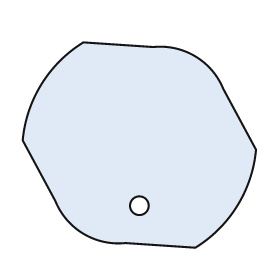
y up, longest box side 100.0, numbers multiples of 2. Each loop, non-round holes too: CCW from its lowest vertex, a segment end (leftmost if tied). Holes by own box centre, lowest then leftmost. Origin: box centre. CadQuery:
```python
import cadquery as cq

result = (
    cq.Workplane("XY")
    .moveTo(24.0, -44.0)
    .threePointArc((42.0, -26.0), (50.0, -2.0))
    .lineTo(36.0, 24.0)
    .threePointArc((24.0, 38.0), (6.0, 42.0))
    .lineTo(-24.0, 44.0)
    .threePointArc((-42.0, 26.0), (-50.0, 2.0))
    .lineTo(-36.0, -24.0)
    .threePointArc((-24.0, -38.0), (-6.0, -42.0))
    .close()
    .moveTo(0.0, -26.0)
    .circle(4.0)
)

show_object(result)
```